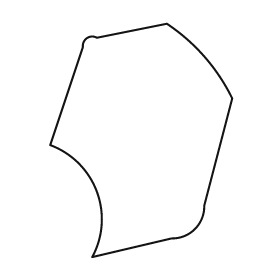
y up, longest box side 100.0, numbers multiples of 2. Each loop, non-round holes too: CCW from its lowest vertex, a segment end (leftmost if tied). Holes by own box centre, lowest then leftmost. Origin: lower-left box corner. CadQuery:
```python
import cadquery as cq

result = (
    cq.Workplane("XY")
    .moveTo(18.0, 0.0)
    .lineTo(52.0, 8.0)
    .threePointArc((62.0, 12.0), (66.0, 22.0))
    .lineTo(78.0, 68.0)
    .threePointArc((66.0, 86.0), (50.0, 100.0))
    .lineTo(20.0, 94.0)
    .threePointArc((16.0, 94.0), (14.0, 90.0))
    .lineTo(0.0, 48.0)
    .threePointArc((20.0, 28.0), (18.0, 0.0))
    .close()
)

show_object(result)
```